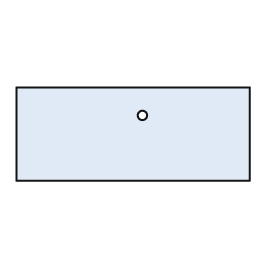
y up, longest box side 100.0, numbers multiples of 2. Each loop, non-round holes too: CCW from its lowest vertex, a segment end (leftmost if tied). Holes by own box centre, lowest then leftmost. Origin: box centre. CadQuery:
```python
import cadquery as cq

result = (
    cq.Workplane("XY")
    .moveTo(-50.0, -20.0)
    .lineTo(50.0, -20.0)
    .lineTo(50.0, 20.0)
    .lineTo(-50.0, 20.0)
    .close()
    .moveTo(4.0, 8.0)
    .circle(2.0)
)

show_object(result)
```